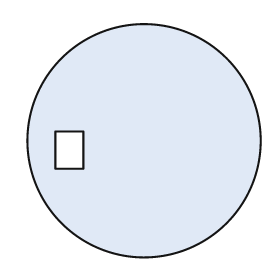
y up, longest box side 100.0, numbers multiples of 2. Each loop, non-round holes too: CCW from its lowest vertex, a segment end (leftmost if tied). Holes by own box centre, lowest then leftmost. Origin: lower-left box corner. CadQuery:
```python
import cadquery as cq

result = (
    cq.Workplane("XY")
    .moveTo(50.0, 50.0)
    .circle(50.0)
    .moveTo(12.0, 38.0)
    .lineTo(24.0, 38.0)
    .lineTo(24.0, 54.0)
    .lineTo(12.0, 54.0)
    .close()
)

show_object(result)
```